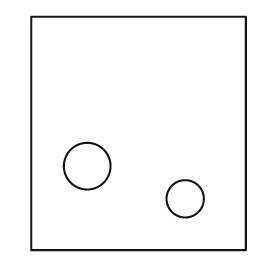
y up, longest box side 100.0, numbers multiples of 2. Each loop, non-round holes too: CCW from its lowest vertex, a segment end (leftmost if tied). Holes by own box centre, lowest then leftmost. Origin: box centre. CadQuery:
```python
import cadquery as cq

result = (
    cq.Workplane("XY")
    .moveTo(-46.0, -50.0)
    .lineTo(46.0, -50.0)
    .lineTo(46.0, 50.0)
    .lineTo(-46.0, 50.0)
    .close()
    .moveTo(20.0, -28.0)
    .circle(8.0)
    .moveTo(-22.0, -14.0)
    .circle(10.0)
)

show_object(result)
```